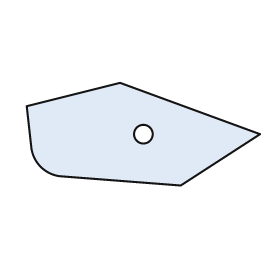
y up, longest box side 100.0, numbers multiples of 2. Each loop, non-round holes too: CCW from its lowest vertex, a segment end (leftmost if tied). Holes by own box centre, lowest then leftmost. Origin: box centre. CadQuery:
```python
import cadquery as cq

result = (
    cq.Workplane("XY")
    .moveTo(16.0, -22.0)
    .lineTo(50.0, 0.0)
    .lineTo(-10.0, 22.0)
    .lineTo(-50.0, 12.0)
    .lineTo(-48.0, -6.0)
    .threePointArc((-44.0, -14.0), (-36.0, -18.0))
    .close()
    .moveTo(0.0, 0.0)
    .circle(4.0)
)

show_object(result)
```